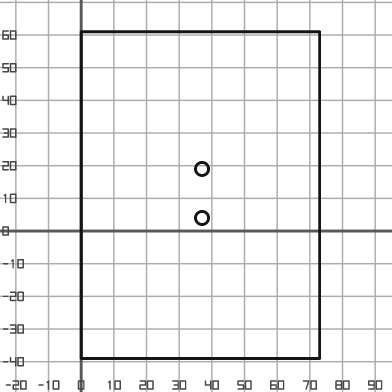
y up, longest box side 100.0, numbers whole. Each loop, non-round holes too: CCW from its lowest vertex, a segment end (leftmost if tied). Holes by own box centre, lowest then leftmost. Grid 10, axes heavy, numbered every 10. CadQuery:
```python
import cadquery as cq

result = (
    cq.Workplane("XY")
    .moveTo(0.0, -39.0)
    .lineTo(73.0, -39.0)
    .lineTo(73.0, 61.0)
    .lineTo(0.0, 61.0)
    .close()
    .moveTo(37.0, 4.0)
    .circle(2.0)
    .moveTo(37.0, 19.0)
    .circle(2.0)
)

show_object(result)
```